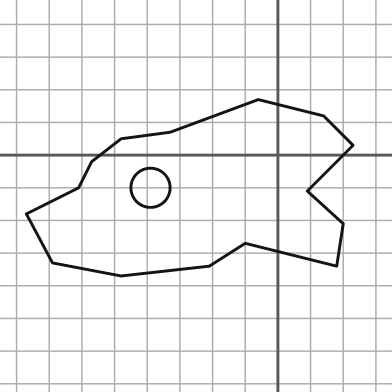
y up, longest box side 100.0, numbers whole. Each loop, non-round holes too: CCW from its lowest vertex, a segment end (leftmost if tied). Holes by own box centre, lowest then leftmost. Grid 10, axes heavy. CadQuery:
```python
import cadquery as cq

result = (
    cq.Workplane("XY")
    .moveTo(-48.0, -37.0)
    .lineTo(-21.0, -34.0)
    .lineTo(-10.0, -27.0)
    .lineTo(18.0, -34.0)
    .lineTo(20.0, -21.0)
    .lineTo(9.0, -11.0)
    .lineTo(23.0, 3.0)
    .lineTo(14.0, 12.0)
    .lineTo(-6.0, 17.0)
    .lineTo(-33.0, 7.0)
    .lineTo(-48.0, 5.0)
    .lineTo(-57.0, -2.0)
    .lineTo(-61.0, -10.0)
    .lineTo(-77.0, -18.0)
    .lineTo(-69.0, -33.0)
    .close()
    .moveTo(-39.0, -10.0)
    .circle(6.0)
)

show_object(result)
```